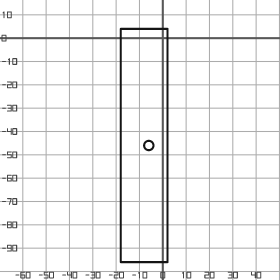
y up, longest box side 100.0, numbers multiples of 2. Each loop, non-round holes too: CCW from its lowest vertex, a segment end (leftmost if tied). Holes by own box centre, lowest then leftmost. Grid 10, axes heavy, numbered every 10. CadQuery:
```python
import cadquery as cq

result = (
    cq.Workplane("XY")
    .moveTo(-18.0, -96.0)
    .lineTo(2.0, -96.0)
    .lineTo(2.0, 4.0)
    .lineTo(-18.0, 4.0)
    .close()
    .moveTo(-6.0, -46.0)
    .circle(2.0)
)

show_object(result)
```